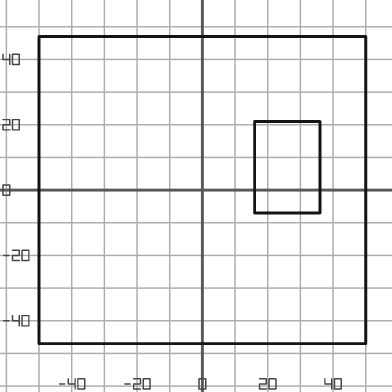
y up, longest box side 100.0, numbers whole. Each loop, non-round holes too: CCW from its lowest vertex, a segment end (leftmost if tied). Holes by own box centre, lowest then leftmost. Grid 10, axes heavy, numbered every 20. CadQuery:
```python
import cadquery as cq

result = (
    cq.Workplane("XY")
    .moveTo(-50.0, -47.0)
    .lineTo(50.0, -47.0)
    .lineTo(50.0, 47.0)
    .lineTo(-50.0, 47.0)
    .close()
    .moveTo(16.0, -7.0)
    .lineTo(36.0, -7.0)
    .lineTo(36.0, 21.0)
    .lineTo(16.0, 21.0)
    .close()
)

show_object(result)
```